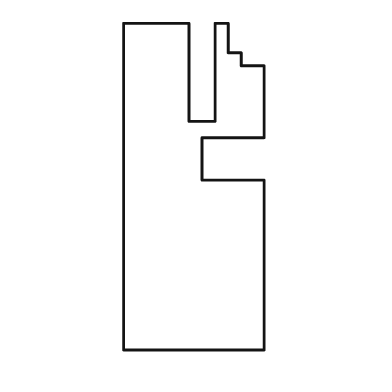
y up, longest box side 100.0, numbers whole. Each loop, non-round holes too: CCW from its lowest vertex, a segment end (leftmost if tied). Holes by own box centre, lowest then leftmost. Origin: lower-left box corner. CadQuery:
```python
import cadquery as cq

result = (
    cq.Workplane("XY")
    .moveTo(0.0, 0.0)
    .lineTo(43.0, 0.0)
    .lineTo(43.0, 52.0)
    .lineTo(24.0, 52.0)
    .lineTo(24.0, 65.0)
    .lineTo(43.0, 65.0)
    .lineTo(43.0, 87.0)
    .lineTo(36.0, 87.0)
    .lineTo(36.0, 91.0)
    .lineTo(32.0, 91.0)
    .lineTo(32.0, 100.0)
    .lineTo(28.0, 100.0)
    .lineTo(28.0, 70.0)
    .lineTo(20.0, 70.0)
    .lineTo(20.0, 100.0)
    .lineTo(0.0, 100.0)
    .close()
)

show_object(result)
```